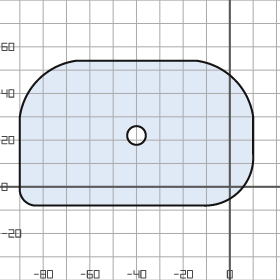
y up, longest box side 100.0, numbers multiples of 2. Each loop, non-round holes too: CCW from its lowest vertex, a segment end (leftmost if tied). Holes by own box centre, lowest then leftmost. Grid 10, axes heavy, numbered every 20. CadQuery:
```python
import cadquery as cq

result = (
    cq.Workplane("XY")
    .moveTo(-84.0, -8.0)
    .lineTo(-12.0, -8.0)
    .threePointArc((4.0, -2.0), (10.0, 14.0))
    .lineTo(10.0, 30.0)
    .threePointArc((2.0, 46.0), (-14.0, 54.0))
    .lineTo(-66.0, 54.0)
    .threePointArc((-82.0, 46.0), (-90.0, 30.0))
    .lineTo(-90.0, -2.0)
    .threePointArc((-88.0, -6.0), (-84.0, -8.0))
    .close()
    .moveTo(-40.0, 22.0)
    .circle(4.0)
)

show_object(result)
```